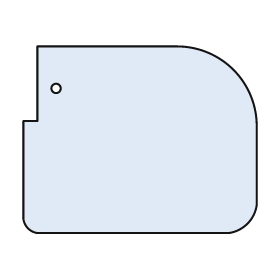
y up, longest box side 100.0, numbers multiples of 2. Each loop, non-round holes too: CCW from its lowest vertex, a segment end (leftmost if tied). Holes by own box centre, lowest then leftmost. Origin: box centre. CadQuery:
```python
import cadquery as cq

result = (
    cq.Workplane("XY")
    .moveTo(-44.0, -40.0)
    .lineTo(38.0, -40.0)
    .threePointArc((46.0, -36.0), (50.0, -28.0))
    .lineTo(50.0, 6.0)
    .threePointArc((40.0, 30.0), (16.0, 40.0))
    .lineTo(-44.0, 40.0)
    .lineTo(-44.0, 8.0)
    .lineTo(-50.0, 8.0)
    .lineTo(-50.0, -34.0)
    .threePointArc((-48.0, -38.0), (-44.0, -40.0))
    .close()
    .moveTo(-36.0, 22.0)
    .circle(2.0)
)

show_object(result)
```